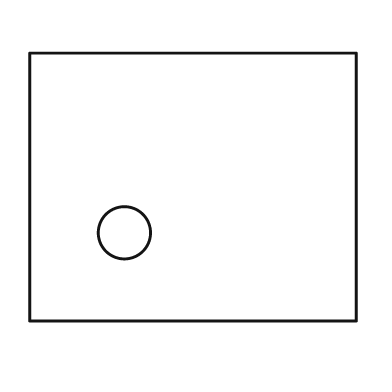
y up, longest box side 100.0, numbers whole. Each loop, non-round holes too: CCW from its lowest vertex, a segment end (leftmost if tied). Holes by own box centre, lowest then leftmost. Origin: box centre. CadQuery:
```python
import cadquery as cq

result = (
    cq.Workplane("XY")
    .moveTo(-50.0, -41.0)
    .lineTo(50.0, -41.0)
    .lineTo(50.0, 41.0)
    .lineTo(-50.0, 41.0)
    .close()
    .moveTo(-21.0, -14.0)
    .circle(8.0)
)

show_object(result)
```